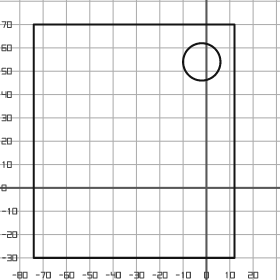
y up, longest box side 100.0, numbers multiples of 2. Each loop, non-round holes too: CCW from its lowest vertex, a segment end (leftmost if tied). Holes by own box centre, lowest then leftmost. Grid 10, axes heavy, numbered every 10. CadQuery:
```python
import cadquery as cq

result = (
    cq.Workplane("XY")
    .moveTo(-74.0, -30.0)
    .lineTo(12.0, -30.0)
    .lineTo(12.0, 70.0)
    .lineTo(-74.0, 70.0)
    .close()
    .moveTo(-2.0, 54.0)
    .circle(8.0)
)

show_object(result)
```